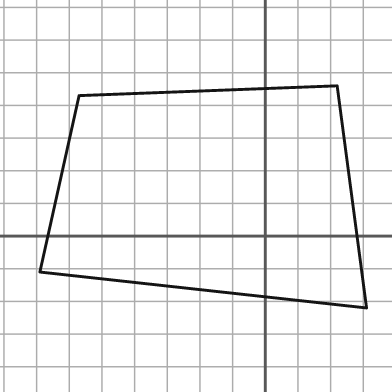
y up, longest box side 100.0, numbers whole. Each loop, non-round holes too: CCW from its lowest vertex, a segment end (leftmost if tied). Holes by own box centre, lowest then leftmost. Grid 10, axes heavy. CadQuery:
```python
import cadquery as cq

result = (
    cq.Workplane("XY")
    .moveTo(31.0, -22.0)
    .lineTo(22.0, 46.0)
    .lineTo(-57.0, 43.0)
    .lineTo(-69.0, -11.0)
    .close()
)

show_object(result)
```